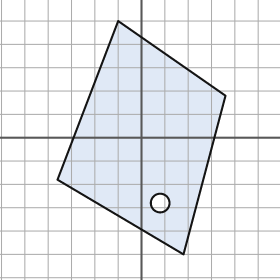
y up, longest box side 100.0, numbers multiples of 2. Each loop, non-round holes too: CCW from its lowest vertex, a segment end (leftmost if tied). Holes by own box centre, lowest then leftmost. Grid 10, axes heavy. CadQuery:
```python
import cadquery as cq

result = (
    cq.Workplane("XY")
    .moveTo(18.0, -50.0)
    .lineTo(36.0, 18.0)
    .lineTo(-10.0, 50.0)
    .lineTo(-36.0, -18.0)
    .close()
    .moveTo(8.0, -28.0)
    .circle(4.0)
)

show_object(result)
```